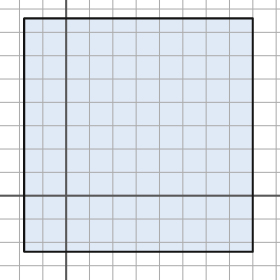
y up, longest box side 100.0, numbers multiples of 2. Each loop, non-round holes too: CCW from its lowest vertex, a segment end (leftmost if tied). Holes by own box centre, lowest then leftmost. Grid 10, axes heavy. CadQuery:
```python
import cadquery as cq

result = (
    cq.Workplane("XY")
    .moveTo(-18.0, -24.0)
    .lineTo(80.0, -24.0)
    .lineTo(80.0, 76.0)
    .lineTo(-18.0, 76.0)
    .close()
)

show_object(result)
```